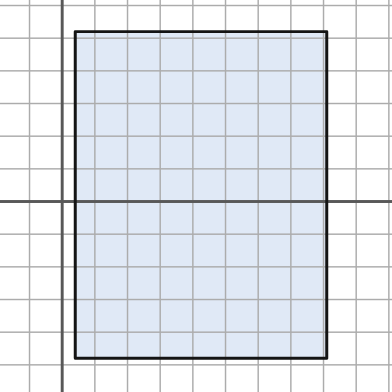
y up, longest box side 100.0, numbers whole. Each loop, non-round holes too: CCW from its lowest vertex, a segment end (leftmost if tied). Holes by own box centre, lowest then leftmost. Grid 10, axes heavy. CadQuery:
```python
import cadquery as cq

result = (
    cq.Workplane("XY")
    .moveTo(4.0, -48.0)
    .lineTo(81.0, -48.0)
    .lineTo(81.0, 52.0)
    .lineTo(4.0, 52.0)
    .close()
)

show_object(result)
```